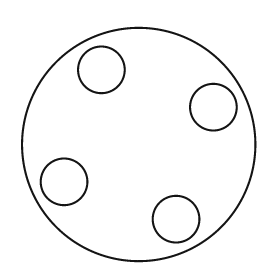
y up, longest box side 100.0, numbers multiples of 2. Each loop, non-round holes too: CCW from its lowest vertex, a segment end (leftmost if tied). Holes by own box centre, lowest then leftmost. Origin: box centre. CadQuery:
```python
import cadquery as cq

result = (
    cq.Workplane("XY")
    .moveTo(0.0, 0.0)
    .circle(50.0)
    .moveTo(16.0, -32.0)
    .circle(10.0)
    .moveTo(-32.0, -16.0)
    .circle(10.0)
    .moveTo(32.0, 16.0)
    .circle(10.0)
    .moveTo(-16.0, 32.0)
    .circle(10.0)
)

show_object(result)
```